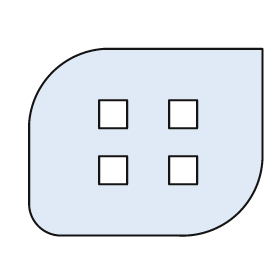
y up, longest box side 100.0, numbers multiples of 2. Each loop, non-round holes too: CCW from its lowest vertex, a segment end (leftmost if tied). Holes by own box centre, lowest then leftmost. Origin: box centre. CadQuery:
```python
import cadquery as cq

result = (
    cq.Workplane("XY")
    .moveTo(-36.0, -40.0)
    .lineTo(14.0, -40.0)
    .threePointArc((40.0, -30.0), (50.0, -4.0))
    .lineTo(50.0, 40.0)
    .lineTo(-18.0, 40.0)
    .threePointArc((-40.0, 30.0), (-50.0, 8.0))
    .lineTo(-50.0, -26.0)
    .threePointArc((-46.0, -36.0), (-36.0, -40.0))
    .close()
    .moveTo(-20.0, -18.0)
    .lineTo(-8.0, -18.0)
    .lineTo(-8.0, -6.0)
    .lineTo(-20.0, -6.0)
    .close()
    .moveTo(10.0, -18.0)
    .lineTo(22.0, -18.0)
    .lineTo(22.0, -6.0)
    .lineTo(10.0, -6.0)
    .close()
    .moveTo(-20.0, 6.0)
    .lineTo(-8.0, 6.0)
    .lineTo(-8.0, 18.0)
    .lineTo(-20.0, 18.0)
    .close()
    .moveTo(10.0, 6.0)
    .lineTo(22.0, 6.0)
    .lineTo(22.0, 18.0)
    .lineTo(10.0, 18.0)
    .close()
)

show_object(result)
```